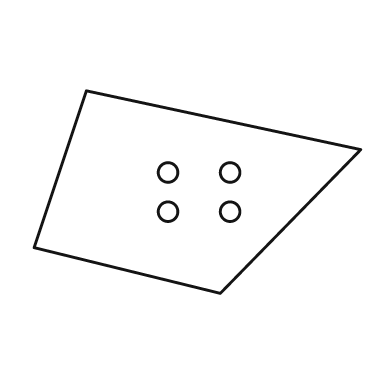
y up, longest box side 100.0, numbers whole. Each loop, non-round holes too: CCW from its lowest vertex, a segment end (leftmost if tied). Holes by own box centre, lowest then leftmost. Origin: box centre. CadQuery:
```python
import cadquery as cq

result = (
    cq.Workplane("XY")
    .moveTo(7.0, -31.0)
    .lineTo(50.0, 13.0)
    .lineTo(-34.0, 31.0)
    .lineTo(-50.0, -17.0)
    .close()
    .moveTo(-9.0, -6.0)
    .circle(3.0)
    .moveTo(10.0, -6.0)
    .circle(3.0)
    .moveTo(-9.0, 6.0)
    .circle(3.0)
    .moveTo(10.0, 6.0)
    .circle(3.0)
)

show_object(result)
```